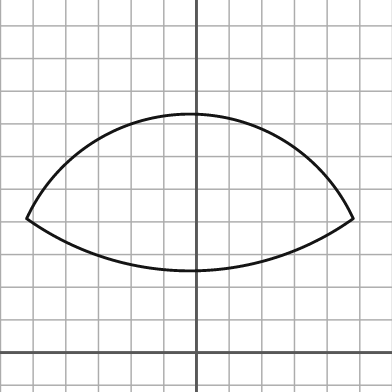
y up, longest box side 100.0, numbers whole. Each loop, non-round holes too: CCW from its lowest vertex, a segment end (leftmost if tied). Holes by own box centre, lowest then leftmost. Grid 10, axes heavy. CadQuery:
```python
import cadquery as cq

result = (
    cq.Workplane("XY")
    .moveTo(-52.0, 41.0)
    .threePointArc((-2.0, 25.0), (48.0, 41.0))
    .threePointArc((-2.0, 73.0), (-52.0, 41.0))
    .close()
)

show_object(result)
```